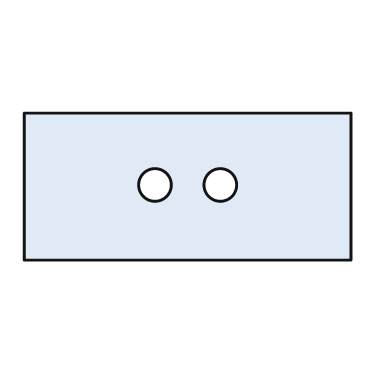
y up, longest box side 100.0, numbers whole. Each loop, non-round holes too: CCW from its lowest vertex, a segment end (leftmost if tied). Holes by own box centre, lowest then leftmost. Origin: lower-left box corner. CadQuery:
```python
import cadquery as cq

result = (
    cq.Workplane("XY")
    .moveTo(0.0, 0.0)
    .lineTo(100.0, 0.0)
    .lineTo(100.0, 45.0)
    .lineTo(0.0, 45.0)
    .close()
    .moveTo(40.0, 23.0)
    .circle(5.0)
    .moveTo(60.0, 23.0)
    .circle(5.0)
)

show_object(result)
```